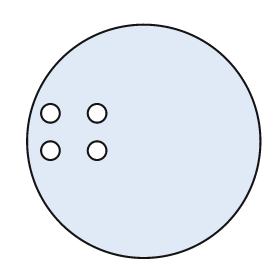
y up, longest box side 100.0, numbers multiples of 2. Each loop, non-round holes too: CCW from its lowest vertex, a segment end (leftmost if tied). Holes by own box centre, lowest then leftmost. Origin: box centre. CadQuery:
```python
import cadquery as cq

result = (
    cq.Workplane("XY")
    .moveTo(0.0, 0.0)
    .circle(50.0)
    .moveTo(-40.0, -4.0)
    .circle(4.0)
    .moveTo(-20.0, -4.0)
    .circle(4.0)
    .moveTo(-40.0, 12.0)
    .circle(4.0)
    .moveTo(-20.0, 12.0)
    .circle(4.0)
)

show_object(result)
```